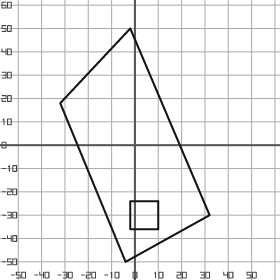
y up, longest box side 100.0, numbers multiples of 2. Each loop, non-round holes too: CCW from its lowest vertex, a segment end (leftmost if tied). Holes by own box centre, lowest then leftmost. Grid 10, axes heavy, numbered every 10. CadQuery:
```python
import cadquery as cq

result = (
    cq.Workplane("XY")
    .moveTo(-4.0, -50.0)
    .lineTo(32.0, -30.0)
    .lineTo(-2.0, 50.0)
    .lineTo(-32.0, 18.0)
    .close()
    .moveTo(-2.0, -36.0)
    .lineTo(10.0, -36.0)
    .lineTo(10.0, -24.0)
    .lineTo(-2.0, -24.0)
    .close()
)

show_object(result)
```